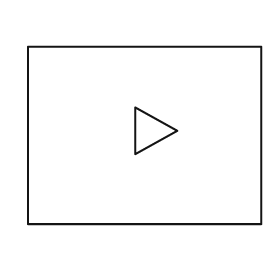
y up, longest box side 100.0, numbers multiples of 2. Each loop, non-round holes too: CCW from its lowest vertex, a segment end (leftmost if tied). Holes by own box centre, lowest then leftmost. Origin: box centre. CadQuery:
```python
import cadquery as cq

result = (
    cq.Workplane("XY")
    .moveTo(-50.0, -38.0)
    .lineTo(50.0, -38.0)
    .lineTo(50.0, 38.0)
    .lineTo(-50.0, 38.0)
    .close()
    .moveTo(-4.0, -8.0)
    .lineTo(14.0, 2.0)
    .lineTo(-4.0, 12.0)
    .close()
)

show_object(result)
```